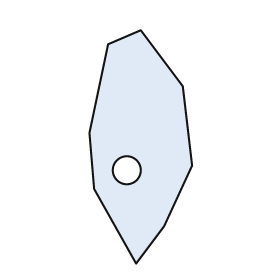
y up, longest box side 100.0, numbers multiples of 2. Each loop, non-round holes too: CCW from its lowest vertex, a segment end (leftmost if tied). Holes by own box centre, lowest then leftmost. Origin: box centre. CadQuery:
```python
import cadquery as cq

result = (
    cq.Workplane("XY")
    .moveTo(-2.0, -50.0)
    .lineTo(10.0, -34.0)
    .lineTo(22.0, -8.0)
    .lineTo(18.0, 26.0)
    .lineTo(0.0, 50.0)
    .lineTo(-14.0, 44.0)
    .lineTo(-22.0, 6.0)
    .lineTo(-20.0, -18.0)
    .close()
    .moveTo(-6.0, -10.0)
    .circle(6.0)
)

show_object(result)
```